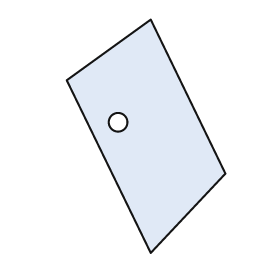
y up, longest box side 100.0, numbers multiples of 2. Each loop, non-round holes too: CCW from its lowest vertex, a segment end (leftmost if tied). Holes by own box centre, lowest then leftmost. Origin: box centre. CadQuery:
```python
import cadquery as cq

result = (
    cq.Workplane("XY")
    .moveTo(2.0, -50.0)
    .lineTo(34.0, -16.0)
    .lineTo(2.0, 50.0)
    .lineTo(-34.0, 24.0)
    .close()
    .moveTo(-12.0, 6.0)
    .circle(4.0)
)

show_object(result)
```